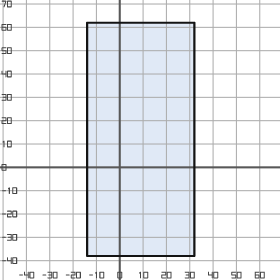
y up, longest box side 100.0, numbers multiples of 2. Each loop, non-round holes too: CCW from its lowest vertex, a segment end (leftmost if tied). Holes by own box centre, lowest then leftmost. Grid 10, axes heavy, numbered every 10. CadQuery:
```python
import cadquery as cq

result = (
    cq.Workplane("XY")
    .moveTo(-14.0, -38.0)
    .lineTo(32.0, -38.0)
    .lineTo(32.0, 62.0)
    .lineTo(-14.0, 62.0)
    .close()
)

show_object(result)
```